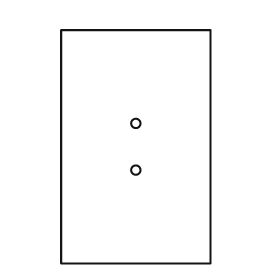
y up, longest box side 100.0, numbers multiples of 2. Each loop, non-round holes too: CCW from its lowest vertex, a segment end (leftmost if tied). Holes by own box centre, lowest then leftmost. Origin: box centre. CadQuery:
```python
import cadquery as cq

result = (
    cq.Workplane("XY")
    .moveTo(-32.0, -50.0)
    .lineTo(32.0, -50.0)
    .lineTo(32.0, 50.0)
    .lineTo(-32.0, 50.0)
    .close()
    .moveTo(0.0, -10.0)
    .circle(2.0)
    .moveTo(0.0, 10.0)
    .circle(2.0)
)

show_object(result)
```